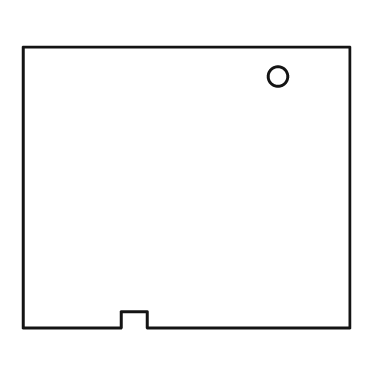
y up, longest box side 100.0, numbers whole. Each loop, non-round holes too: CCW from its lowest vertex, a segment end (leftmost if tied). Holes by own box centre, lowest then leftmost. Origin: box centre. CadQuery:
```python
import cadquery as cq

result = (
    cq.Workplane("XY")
    .moveTo(-50.0, -43.0)
    .lineTo(-20.0, -43.0)
    .lineTo(-20.0, -38.0)
    .lineTo(-12.0, -38.0)
    .lineTo(-12.0, -43.0)
    .lineTo(50.0, -43.0)
    .lineTo(50.0, 43.0)
    .lineTo(-50.0, 43.0)
    .close()
    .moveTo(28.0, 34.0)
    .circle(3.0)
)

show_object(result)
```